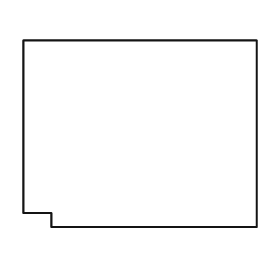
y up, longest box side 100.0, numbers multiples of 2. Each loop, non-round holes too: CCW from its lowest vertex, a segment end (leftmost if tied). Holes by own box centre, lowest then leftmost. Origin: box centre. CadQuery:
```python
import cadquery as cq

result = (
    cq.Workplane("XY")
    .moveTo(-38.0, -40.0)
    .lineTo(50.0, -40.0)
    .lineTo(50.0, 40.0)
    .lineTo(-50.0, 40.0)
    .lineTo(-50.0, -34.0)
    .lineTo(-38.0, -34.0)
    .close()
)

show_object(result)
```